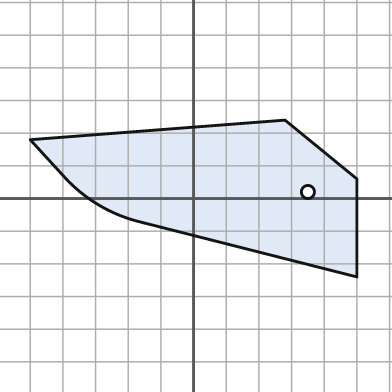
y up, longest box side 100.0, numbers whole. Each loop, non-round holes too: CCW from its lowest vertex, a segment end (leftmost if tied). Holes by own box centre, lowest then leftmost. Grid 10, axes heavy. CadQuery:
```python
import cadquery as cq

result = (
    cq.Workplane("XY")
    .moveTo(50.0, -24.0)
    .lineTo(50.0, 6.0)
    .lineTo(28.0, 24.0)
    .lineTo(-50.0, 18.0)
    .lineTo(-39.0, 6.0)
    .threePointArc((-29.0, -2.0), (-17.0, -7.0))
    .close()
    .moveTo(35.0, 2.0)
    .circle(2.0)
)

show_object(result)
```